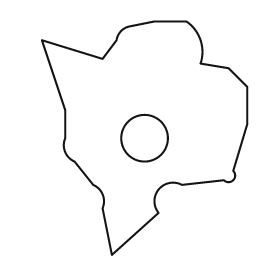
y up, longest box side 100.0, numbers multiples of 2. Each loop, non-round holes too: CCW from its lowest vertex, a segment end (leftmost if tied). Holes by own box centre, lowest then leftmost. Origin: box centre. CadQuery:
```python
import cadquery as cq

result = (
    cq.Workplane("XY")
    .moveTo(-14.0, -50.0)
    .lineTo(6.0, -32.0)
    .threePointArc((6.0, -22.0), (16.0, -20.0))
    .lineTo(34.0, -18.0)
    .threePointArc((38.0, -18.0), (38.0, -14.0))
    .lineTo(44.0, 6.0)
    .lineTo(44.0, 22.0)
    .lineTo(36.0, 30.0)
    .lineTo(24.0, 32.0)
    .threePointArc((24.0, 42.0), (18.0, 50.0))
    .lineTo(4.0, 50.0)
    .lineTo(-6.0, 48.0)
    .threePointArc((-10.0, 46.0), (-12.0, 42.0))
    .lineTo(-18.0, 34.0)
    .lineTo(-44.0, 42.0)
    .lineTo(-34.0, 12.0)
    .lineTo(-34.0, 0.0)
    .threePointArc((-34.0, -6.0), (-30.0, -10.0))
    .lineTo(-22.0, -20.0)
    .threePointArc((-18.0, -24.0), (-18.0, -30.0))
    .close()
    .moveTo(0.0, 0.0)
    .circle(10.0)
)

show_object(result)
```